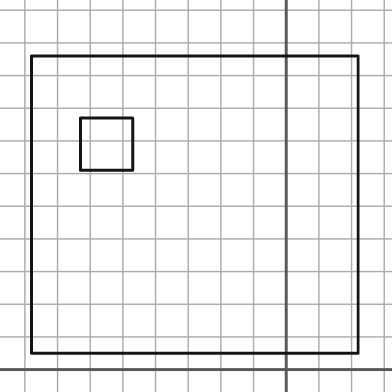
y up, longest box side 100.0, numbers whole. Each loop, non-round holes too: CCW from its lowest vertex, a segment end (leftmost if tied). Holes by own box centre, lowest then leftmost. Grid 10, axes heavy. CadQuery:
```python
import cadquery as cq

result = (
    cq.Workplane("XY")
    .moveTo(-78.0, 5.0)
    .lineTo(22.0, 5.0)
    .lineTo(22.0, 96.0)
    .lineTo(-78.0, 96.0)
    .close()
    .moveTo(-63.0, 61.0)
    .lineTo(-47.0, 61.0)
    .lineTo(-47.0, 77.0)
    .lineTo(-63.0, 77.0)
    .close()
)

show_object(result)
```